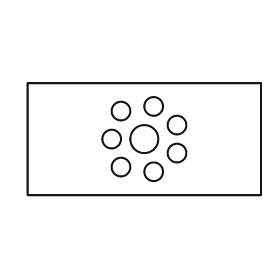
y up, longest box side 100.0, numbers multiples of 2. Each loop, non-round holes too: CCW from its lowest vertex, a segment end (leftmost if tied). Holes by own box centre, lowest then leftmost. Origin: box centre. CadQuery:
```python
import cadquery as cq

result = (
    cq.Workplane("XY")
    .moveTo(-50.0, -24.0)
    .lineTo(50.0, -24.0)
    .lineTo(50.0, 24.0)
    .lineTo(-50.0, 24.0)
    .close()
    .moveTo(4.0, -14.0)
    .circle(4.0)
    .moveTo(-10.0, -12.0)
    .circle(4.0)
    .moveTo(14.0, -6.0)
    .circle(4.0)
    .moveTo(-14.0, 0.0)
    .circle(4.0)
    .moveTo(0.0, 0.0)
    .circle(6.0)
    .moveTo(14.0, 6.0)
    .circle(4.0)
    .moveTo(-10.0, 12.0)
    .circle(4.0)
    .moveTo(4.0, 14.0)
    .circle(4.0)
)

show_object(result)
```